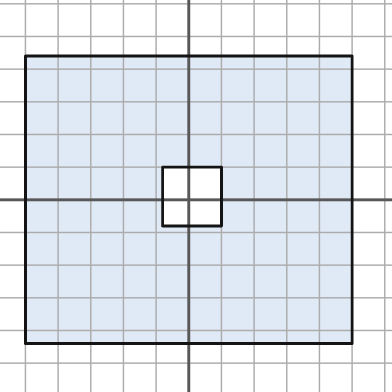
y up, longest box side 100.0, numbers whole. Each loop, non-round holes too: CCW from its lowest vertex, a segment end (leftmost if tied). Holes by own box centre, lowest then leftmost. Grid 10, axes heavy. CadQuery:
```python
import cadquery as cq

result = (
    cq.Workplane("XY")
    .moveTo(-50.0, -44.0)
    .lineTo(50.0, -44.0)
    .lineTo(50.0, 44.0)
    .lineTo(-50.0, 44.0)
    .close()
    .moveTo(-8.0, -8.0)
    .lineTo(10.0, -8.0)
    .lineTo(10.0, 10.0)
    .lineTo(-8.0, 10.0)
    .close()
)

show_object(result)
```